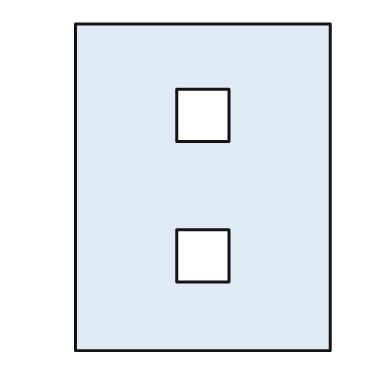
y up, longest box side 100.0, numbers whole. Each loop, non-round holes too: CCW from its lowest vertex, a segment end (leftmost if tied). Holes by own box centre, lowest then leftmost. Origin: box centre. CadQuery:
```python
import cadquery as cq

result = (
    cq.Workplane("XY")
    .moveTo(-39.0, -50.0)
    .lineTo(39.0, -50.0)
    .lineTo(39.0, 50.0)
    .lineTo(-39.0, 50.0)
    .close()
    .moveTo(-8.0, -29.0)
    .lineTo(8.0, -29.0)
    .lineTo(8.0, -13.0)
    .lineTo(-8.0, -13.0)
    .close()
    .moveTo(-8.0, 14.0)
    .lineTo(8.0, 14.0)
    .lineTo(8.0, 30.0)
    .lineTo(-8.0, 30.0)
    .close()
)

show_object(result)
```